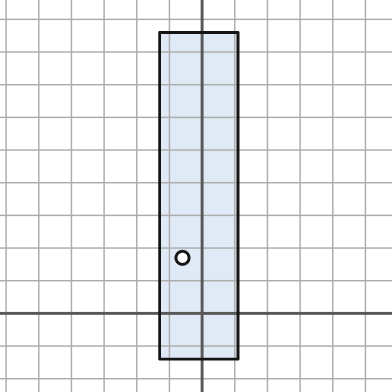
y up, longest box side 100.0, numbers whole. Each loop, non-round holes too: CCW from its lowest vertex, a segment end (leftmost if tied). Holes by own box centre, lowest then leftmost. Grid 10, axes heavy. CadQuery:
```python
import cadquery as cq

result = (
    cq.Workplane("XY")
    .moveTo(-13.0, -14.0)
    .lineTo(11.0, -14.0)
    .lineTo(11.0, 86.0)
    .lineTo(-13.0, 86.0)
    .close()
    .moveTo(-6.0, 17.0)
    .circle(2.0)
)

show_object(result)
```